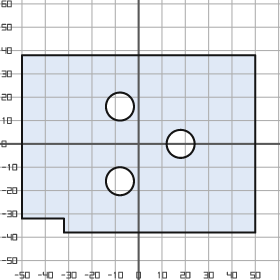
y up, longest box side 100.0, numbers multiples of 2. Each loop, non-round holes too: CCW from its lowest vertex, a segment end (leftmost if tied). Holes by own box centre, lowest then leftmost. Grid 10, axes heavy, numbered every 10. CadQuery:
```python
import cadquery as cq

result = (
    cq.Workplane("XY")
    .moveTo(-32.0, -38.0)
    .lineTo(50.0, -38.0)
    .lineTo(50.0, 38.0)
    .lineTo(-50.0, 38.0)
    .lineTo(-50.0, -32.0)
    .lineTo(-32.0, -32.0)
    .close()
    .moveTo(-8.0, -16.0)
    .circle(6.0)
    .moveTo(18.0, 0.0)
    .circle(6.0)
    .moveTo(-8.0, 16.0)
    .circle(6.0)
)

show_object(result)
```